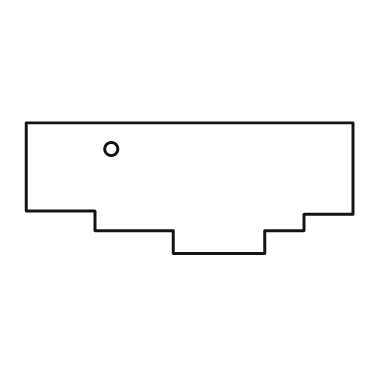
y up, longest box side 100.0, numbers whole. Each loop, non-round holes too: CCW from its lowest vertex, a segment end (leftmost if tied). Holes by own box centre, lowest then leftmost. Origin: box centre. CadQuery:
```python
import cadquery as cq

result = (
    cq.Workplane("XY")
    .moveTo(-5.0, -20.0)
    .lineTo(23.0, -20.0)
    .lineTo(23.0, -13.0)
    .lineTo(35.0, -13.0)
    .lineTo(35.0, -8.0)
    .lineTo(50.0, -8.0)
    .lineTo(50.0, 20.0)
    .lineTo(-50.0, 20.0)
    .lineTo(-50.0, -7.0)
    .lineTo(-29.0, -7.0)
    .lineTo(-29.0, -13.0)
    .lineTo(-5.0, -13.0)
    .close()
    .moveTo(-24.0, 12.0)
    .circle(2.0)
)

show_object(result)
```